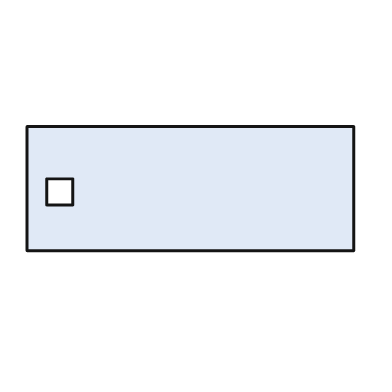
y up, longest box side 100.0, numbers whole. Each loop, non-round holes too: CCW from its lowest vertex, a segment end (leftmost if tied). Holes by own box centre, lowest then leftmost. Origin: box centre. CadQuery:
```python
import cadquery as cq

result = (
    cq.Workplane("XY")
    .moveTo(-50.0, -19.0)
    .lineTo(50.0, -19.0)
    .lineTo(50.0, 19.0)
    .lineTo(-50.0, 19.0)
    .close()
    .moveTo(-44.0, -5.0)
    .lineTo(-36.0, -5.0)
    .lineTo(-36.0, 3.0)
    .lineTo(-44.0, 3.0)
    .close()
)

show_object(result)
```